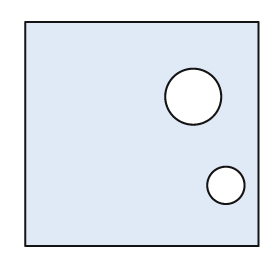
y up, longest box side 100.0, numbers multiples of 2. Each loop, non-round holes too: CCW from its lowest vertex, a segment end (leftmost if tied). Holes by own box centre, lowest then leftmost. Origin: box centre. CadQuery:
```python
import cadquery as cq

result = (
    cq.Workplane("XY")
    .moveTo(-50.0, -48.0)
    .lineTo(50.0, -48.0)
    .lineTo(50.0, 48.0)
    .lineTo(-50.0, 48.0)
    .close()
    .moveTo(36.0, -22.0)
    .circle(8.0)
    .moveTo(22.0, 16.0)
    .circle(12.0)
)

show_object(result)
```